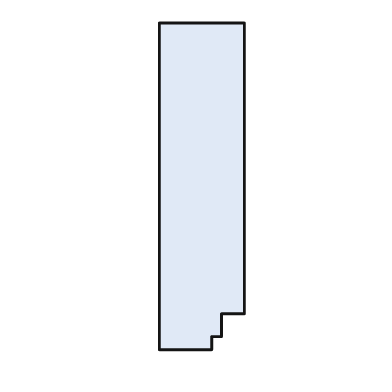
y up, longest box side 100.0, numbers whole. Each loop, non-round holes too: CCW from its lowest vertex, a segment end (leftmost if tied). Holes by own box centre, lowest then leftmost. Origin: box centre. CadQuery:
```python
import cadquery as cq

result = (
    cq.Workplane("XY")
    .moveTo(-13.0, -50.0)
    .lineTo(3.0, -50.0)
    .lineTo(3.0, -46.0)
    .lineTo(6.0, -46.0)
    .lineTo(6.0, -39.0)
    .lineTo(13.0, -39.0)
    .lineTo(13.0, 50.0)
    .lineTo(-13.0, 50.0)
    .close()
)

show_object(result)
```